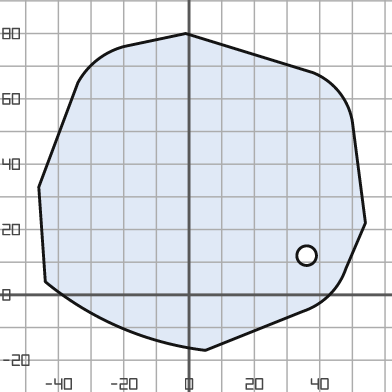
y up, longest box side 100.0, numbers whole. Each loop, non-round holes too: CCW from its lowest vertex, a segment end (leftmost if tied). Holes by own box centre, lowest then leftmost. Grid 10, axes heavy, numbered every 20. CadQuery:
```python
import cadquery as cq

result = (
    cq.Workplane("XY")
    .moveTo(5.0, -17.0)
    .lineTo(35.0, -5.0)
    .threePointArc((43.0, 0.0), (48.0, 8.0))
    .lineTo(54.0, 22.0)
    .lineTo(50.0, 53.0)
    .threePointArc((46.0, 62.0), (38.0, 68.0))
    .lineTo(-1.0, 80.0)
    .lineTo(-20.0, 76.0)
    .threePointArc((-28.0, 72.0), (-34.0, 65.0))
    .lineTo(-46.0, 33.0)
    .lineTo(-44.0, 4.0)
    .threePointArc((-21.0, -10.0), (5.0, -17.0))
    .close()
    .moveTo(36.0, 12.0)
    .circle(3.0)
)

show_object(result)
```